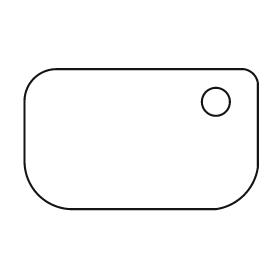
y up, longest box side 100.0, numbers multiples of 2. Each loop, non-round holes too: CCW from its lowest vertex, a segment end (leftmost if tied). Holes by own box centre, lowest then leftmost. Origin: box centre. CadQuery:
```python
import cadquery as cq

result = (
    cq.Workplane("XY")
    .moveTo(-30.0, -30.0)
    .lineTo(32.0, -30.0)
    .threePointArc((44.0, -24.0), (50.0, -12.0))
    .lineTo(50.0, 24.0)
    .threePointArc((48.0, 28.0), (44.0, 30.0))
    .lineTo(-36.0, 30.0)
    .threePointArc((-46.0, 26.0), (-50.0, 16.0))
    .lineTo(-50.0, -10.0)
    .threePointArc((-44.0, -24.0), (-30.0, -30.0))
    .close()
    .moveTo(32.0, 16.0)
    .circle(6.0)
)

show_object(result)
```